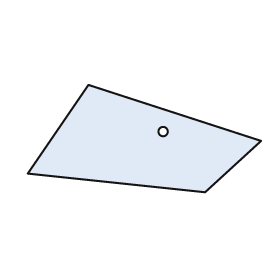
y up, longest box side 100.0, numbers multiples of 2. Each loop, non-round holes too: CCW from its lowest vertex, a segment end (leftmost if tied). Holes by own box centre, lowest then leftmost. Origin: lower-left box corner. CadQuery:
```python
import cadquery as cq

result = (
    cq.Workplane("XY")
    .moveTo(76.0, 0.0)
    .lineTo(100.0, 22.0)
    .lineTo(26.0, 46.0)
    .lineTo(0.0, 8.0)
    .close()
    .moveTo(58.0, 26.0)
    .circle(2.0)
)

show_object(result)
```